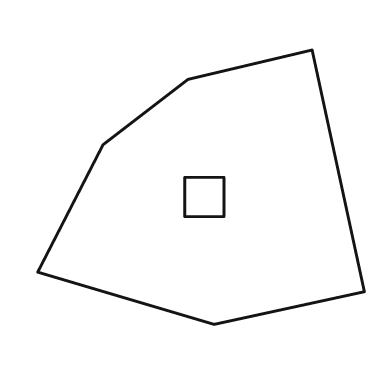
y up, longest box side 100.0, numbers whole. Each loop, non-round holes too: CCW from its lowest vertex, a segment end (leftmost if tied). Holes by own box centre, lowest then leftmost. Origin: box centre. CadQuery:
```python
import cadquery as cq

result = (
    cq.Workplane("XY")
    .moveTo(4.0, -42.0)
    .lineTo(50.0, -32.0)
    .lineTo(34.0, 42.0)
    .lineTo(-4.0, 33.0)
    .lineTo(-30.0, 13.0)
    .lineTo(-50.0, -26.0)
    .close()
    .moveTo(-5.0, -9.0)
    .lineTo(7.0, -9.0)
    .lineTo(7.0, 3.0)
    .lineTo(-5.0, 3.0)
    .close()
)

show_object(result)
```